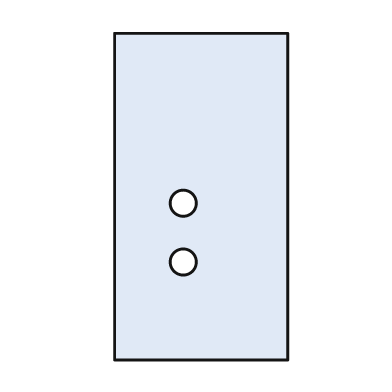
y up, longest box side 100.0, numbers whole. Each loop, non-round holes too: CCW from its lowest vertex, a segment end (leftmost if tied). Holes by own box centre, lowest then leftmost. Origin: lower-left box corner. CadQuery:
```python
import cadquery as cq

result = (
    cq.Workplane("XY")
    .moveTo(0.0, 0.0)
    .lineTo(53.0, 0.0)
    .lineTo(53.0, 100.0)
    .lineTo(0.0, 100.0)
    .close()
    .moveTo(21.0, 30.0)
    .circle(4.0)
    .moveTo(21.0, 48.0)
    .circle(4.0)
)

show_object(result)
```